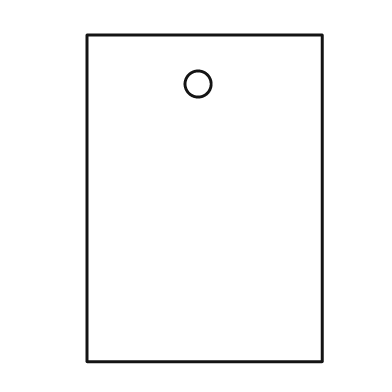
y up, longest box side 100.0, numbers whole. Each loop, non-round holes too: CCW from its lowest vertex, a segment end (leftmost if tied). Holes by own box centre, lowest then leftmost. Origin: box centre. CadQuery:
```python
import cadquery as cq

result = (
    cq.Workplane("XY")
    .moveTo(-36.0, -50.0)
    .lineTo(36.0, -50.0)
    .lineTo(36.0, 50.0)
    .lineTo(-36.0, 50.0)
    .close()
    .moveTo(-2.0, 35.0)
    .circle(4.0)
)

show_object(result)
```